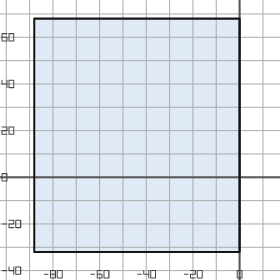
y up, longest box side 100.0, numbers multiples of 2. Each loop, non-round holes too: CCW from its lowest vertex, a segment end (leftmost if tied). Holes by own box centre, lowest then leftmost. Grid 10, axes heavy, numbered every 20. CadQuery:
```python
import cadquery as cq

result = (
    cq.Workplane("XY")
    .moveTo(-88.0, -32.0)
    .lineTo(0.0, -32.0)
    .lineTo(0.0, 68.0)
    .lineTo(-88.0, 68.0)
    .close()
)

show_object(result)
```